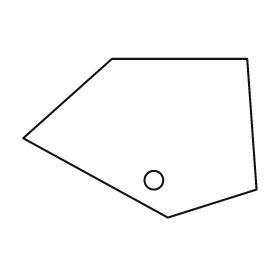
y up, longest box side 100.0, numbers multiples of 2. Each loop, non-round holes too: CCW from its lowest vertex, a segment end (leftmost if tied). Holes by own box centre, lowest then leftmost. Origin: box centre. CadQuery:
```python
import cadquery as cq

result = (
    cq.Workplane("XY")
    .moveTo(12.0, -34.0)
    .lineTo(50.0, -22.0)
    .lineTo(46.0, 34.0)
    .lineTo(-12.0, 34.0)
    .lineTo(-50.0, 0.0)
    .close()
    .moveTo(6.0, -18.0)
    .circle(4.0)
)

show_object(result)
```